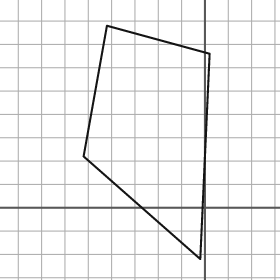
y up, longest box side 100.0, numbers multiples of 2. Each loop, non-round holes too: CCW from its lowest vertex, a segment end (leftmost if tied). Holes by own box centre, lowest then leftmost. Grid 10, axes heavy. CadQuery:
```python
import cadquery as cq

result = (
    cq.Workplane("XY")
    .moveTo(-2.0, -22.0)
    .lineTo(2.0, 66.0)
    .lineTo(-42.0, 78.0)
    .lineTo(-52.0, 22.0)
    .close()
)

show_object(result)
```